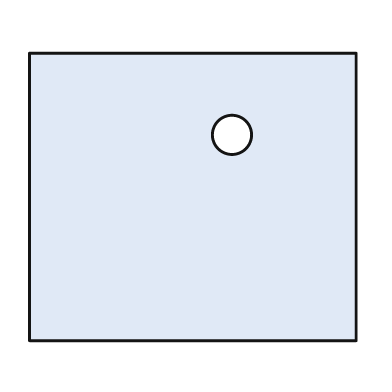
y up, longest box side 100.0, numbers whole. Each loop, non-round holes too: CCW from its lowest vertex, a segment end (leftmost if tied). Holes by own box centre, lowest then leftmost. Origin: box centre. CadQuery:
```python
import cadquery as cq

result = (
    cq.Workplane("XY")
    .moveTo(-50.0, -44.0)
    .lineTo(50.0, -44.0)
    .lineTo(50.0, 44.0)
    .lineTo(-50.0, 44.0)
    .close()
    .moveTo(12.0, 19.0)
    .circle(6.0)
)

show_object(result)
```